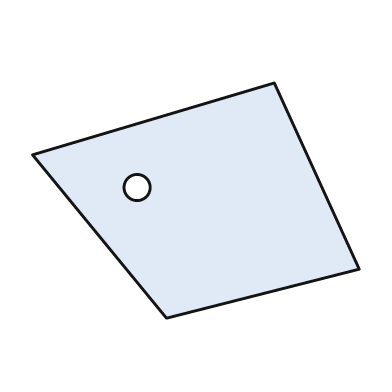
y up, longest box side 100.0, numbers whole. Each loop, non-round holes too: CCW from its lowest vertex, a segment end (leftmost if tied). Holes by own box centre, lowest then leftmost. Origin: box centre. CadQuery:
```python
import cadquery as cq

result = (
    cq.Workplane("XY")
    .moveTo(-9.0, -36.0)
    .lineTo(50.0, -21.0)
    .lineTo(24.0, 36.0)
    .lineTo(-50.0, 14.0)
    .close()
    .moveTo(-18.0, 4.0)
    .circle(4.0)
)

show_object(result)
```